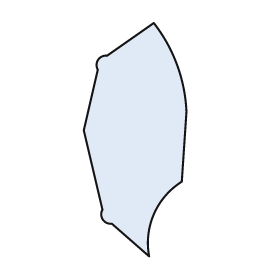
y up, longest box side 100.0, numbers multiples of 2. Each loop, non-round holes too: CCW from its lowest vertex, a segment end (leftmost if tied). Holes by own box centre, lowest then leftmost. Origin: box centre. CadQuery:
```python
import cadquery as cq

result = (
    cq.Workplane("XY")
    .moveTo(6.0, -50.0)
    .threePointArc((8.0, -32.0), (20.0, -18.0))
    .lineTo(22.0, 12.0)
    .threePointArc((18.0, 32.0), (8.0, 50.0))
    .lineTo(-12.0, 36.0)
    .threePointArc((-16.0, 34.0), (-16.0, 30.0))
    .lineTo(-22.0, 4.0)
    .lineTo(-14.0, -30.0)
    .threePointArc((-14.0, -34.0), (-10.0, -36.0))
    .close()
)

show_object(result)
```